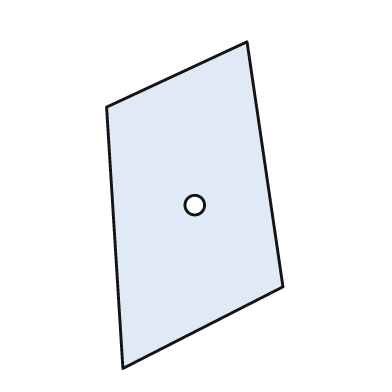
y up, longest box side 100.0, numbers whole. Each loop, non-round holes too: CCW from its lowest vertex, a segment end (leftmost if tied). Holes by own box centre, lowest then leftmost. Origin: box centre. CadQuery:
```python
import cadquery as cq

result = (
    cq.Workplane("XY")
    .moveTo(-22.0, -50.0)
    .lineTo(27.0, -25.0)
    .lineTo(16.0, 50.0)
    .lineTo(-27.0, 30.0)
    .close()
    .moveTo(0.0, 0.0)
    .circle(3.0)
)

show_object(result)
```